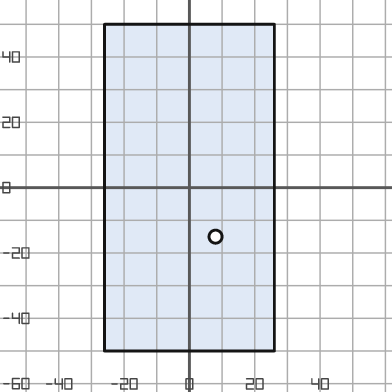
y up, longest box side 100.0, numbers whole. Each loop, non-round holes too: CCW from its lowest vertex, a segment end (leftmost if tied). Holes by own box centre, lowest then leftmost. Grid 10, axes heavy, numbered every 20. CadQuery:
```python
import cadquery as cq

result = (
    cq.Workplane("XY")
    .moveTo(-26.0, -50.0)
    .lineTo(26.0, -50.0)
    .lineTo(26.0, 50.0)
    .lineTo(-26.0, 50.0)
    .close()
    .moveTo(8.0, -15.0)
    .circle(2.0)
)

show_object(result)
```